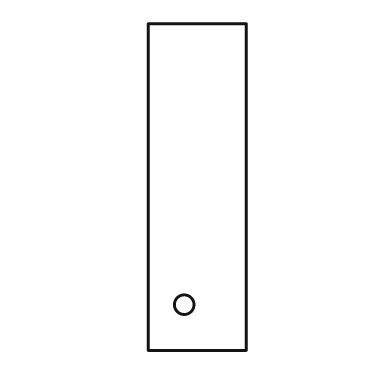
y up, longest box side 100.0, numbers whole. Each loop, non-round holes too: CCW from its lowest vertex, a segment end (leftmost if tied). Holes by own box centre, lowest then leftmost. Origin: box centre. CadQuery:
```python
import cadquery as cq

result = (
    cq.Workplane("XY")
    .moveTo(-15.0, -50.0)
    .lineTo(15.0, -50.0)
    .lineTo(15.0, 50.0)
    .lineTo(-15.0, 50.0)
    .close()
    .moveTo(-4.0, -36.0)
    .circle(3.0)
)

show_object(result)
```